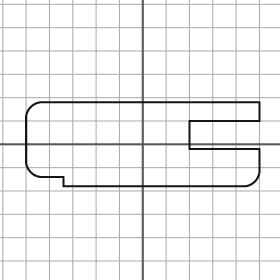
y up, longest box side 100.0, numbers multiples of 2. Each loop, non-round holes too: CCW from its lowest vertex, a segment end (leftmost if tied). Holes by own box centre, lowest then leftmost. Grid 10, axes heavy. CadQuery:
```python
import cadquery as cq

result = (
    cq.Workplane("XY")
    .moveTo(-34.0, -18.0)
    .lineTo(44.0, -18.0)
    .threePointArc((48.0, -16.0), (50.0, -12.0))
    .lineTo(50.0, -2.0)
    .lineTo(20.0, -2.0)
    .lineTo(20.0, 10.0)
    .lineTo(50.0, 10.0)
    .lineTo(50.0, 18.0)
    .lineTo(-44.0, 18.0)
    .threePointArc((-48.0, 16.0), (-50.0, 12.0))
    .lineTo(-50.0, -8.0)
    .threePointArc((-48.0, -12.0), (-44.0, -14.0))
    .lineTo(-34.0, -14.0)
    .close()
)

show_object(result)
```